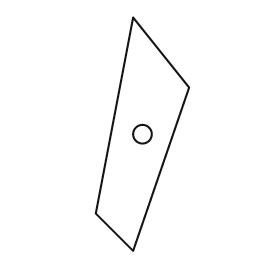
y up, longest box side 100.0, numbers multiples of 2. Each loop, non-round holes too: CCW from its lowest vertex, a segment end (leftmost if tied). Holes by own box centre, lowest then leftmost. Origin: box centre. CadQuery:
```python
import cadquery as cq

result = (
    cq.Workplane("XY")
    .moveTo(-4.0, -50.0)
    .lineTo(20.0, 20.0)
    .lineTo(-4.0, 50.0)
    .lineTo(-20.0, -34.0)
    .close()
    .moveTo(0.0, 0.0)
    .circle(4.0)
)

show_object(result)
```